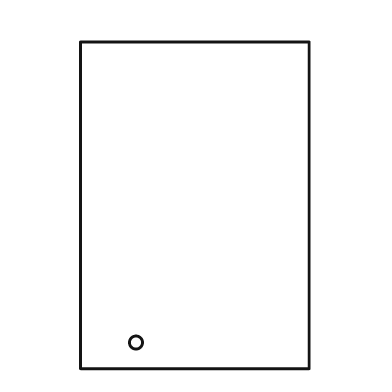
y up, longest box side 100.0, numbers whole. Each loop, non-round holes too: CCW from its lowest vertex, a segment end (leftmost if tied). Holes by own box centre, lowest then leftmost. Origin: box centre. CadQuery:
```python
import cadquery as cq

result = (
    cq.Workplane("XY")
    .moveTo(-35.0, -50.0)
    .lineTo(35.0, -50.0)
    .lineTo(35.0, 50.0)
    .lineTo(-35.0, 50.0)
    .close()
    .moveTo(-18.0, -42.0)
    .circle(2.0)
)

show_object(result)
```